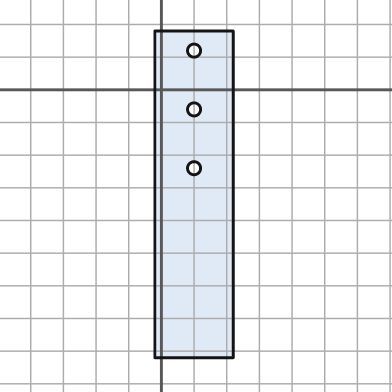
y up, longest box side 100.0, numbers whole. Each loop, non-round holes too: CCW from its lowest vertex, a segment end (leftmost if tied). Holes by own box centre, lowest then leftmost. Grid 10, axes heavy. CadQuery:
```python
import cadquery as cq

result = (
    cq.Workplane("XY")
    .moveTo(-2.0, -82.0)
    .lineTo(22.0, -82.0)
    .lineTo(22.0, 18.0)
    .lineTo(-2.0, 18.0)
    .close()
    .moveTo(10.0, -24.0)
    .circle(2.0)
    .moveTo(10.0, -6.0)
    .circle(2.0)
    .moveTo(10.0, 12.0)
    .circle(2.0)
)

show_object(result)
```